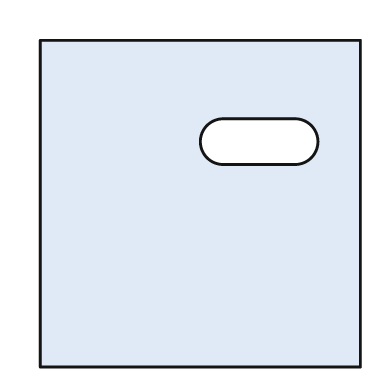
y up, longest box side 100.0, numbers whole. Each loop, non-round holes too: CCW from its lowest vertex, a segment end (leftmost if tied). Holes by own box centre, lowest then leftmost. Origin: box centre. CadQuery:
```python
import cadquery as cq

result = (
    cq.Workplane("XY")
    .moveTo(-49.0, -50.0)
    .lineTo(49.0, -50.0)
    .lineTo(49.0, 50.0)
    .lineTo(-49.0, 50.0)
    .close()
    .moveTo(7.0, 12.0)
    .lineTo(29.0, 12.0)
    .threePointArc((36.0, 19.0), (29.0, 26.0))
    .lineTo(7.0, 26.0)
    .threePointArc((0.0, 19.0), (7.0, 12.0))
    .close()
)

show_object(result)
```